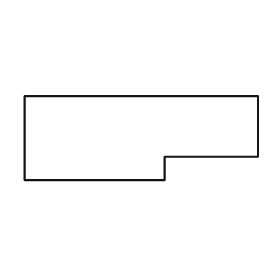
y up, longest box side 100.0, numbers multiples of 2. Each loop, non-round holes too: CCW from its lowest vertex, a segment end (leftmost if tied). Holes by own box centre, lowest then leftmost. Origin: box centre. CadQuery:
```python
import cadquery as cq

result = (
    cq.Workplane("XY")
    .moveTo(-50.0, -18.0)
    .lineTo(10.0, -18.0)
    .lineTo(10.0, -8.0)
    .lineTo(50.0, -8.0)
    .lineTo(50.0, 18.0)
    .lineTo(-50.0, 18.0)
    .close()
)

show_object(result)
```